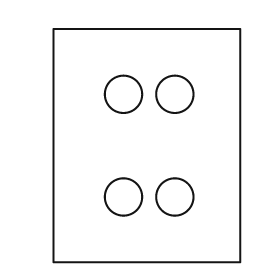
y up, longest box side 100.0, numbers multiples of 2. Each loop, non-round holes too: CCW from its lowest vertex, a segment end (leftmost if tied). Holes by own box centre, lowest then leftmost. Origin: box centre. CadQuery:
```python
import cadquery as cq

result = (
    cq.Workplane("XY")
    .moveTo(-40.0, -50.0)
    .lineTo(40.0, -50.0)
    .lineTo(40.0, 50.0)
    .lineTo(-40.0, 50.0)
    .close()
    .moveTo(-10.0, -22.0)
    .circle(8.0)
    .moveTo(12.0, -22.0)
    .circle(8.0)
    .moveTo(-10.0, 22.0)
    .circle(8.0)
    .moveTo(12.0, 22.0)
    .circle(8.0)
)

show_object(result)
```